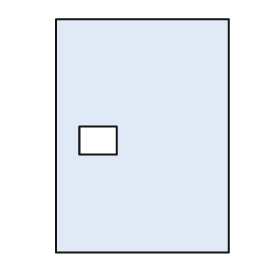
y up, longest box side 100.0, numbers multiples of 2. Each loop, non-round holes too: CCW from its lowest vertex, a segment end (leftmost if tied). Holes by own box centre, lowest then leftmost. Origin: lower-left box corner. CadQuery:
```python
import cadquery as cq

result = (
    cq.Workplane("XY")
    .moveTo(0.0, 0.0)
    .lineTo(74.0, 0.0)
    .lineTo(74.0, 100.0)
    .lineTo(0.0, 100.0)
    .close()
    .moveTo(10.0, 42.0)
    .lineTo(26.0, 42.0)
    .lineTo(26.0, 54.0)
    .lineTo(10.0, 54.0)
    .close()
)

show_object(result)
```